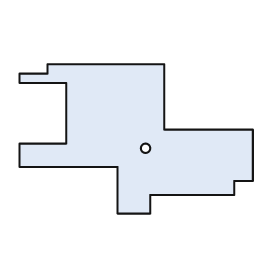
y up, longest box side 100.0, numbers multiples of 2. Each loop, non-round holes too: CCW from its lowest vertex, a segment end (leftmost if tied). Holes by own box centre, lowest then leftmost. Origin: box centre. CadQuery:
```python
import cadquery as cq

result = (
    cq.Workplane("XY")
    .moveTo(-8.0, -32.0)
    .lineTo(6.0, -32.0)
    .lineTo(6.0, -24.0)
    .lineTo(42.0, -24.0)
    .lineTo(42.0, -18.0)
    .lineTo(50.0, -18.0)
    .lineTo(50.0, 4.0)
    .lineTo(12.0, 4.0)
    .lineTo(12.0, 32.0)
    .lineTo(-38.0, 32.0)
    .lineTo(-38.0, 28.0)
    .lineTo(-50.0, 28.0)
    .lineTo(-50.0, 24.0)
    .lineTo(-30.0, 24.0)
    .lineTo(-30.0, -2.0)
    .lineTo(-50.0, -2.0)
    .lineTo(-50.0, -12.0)
    .lineTo(-8.0, -12.0)
    .close()
    .moveTo(4.0, -4.0)
    .circle(2.0)
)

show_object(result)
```